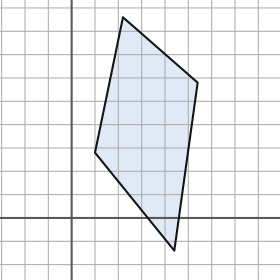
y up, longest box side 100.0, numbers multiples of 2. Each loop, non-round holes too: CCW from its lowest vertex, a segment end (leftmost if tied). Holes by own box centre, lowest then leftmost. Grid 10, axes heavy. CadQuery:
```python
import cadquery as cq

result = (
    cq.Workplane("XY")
    .moveTo(44.0, -14.0)
    .lineTo(54.0, 58.0)
    .lineTo(22.0, 86.0)
    .lineTo(10.0, 28.0)
    .close()
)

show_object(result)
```